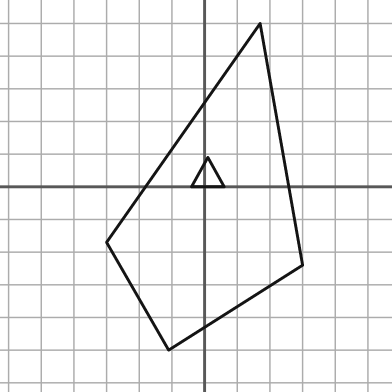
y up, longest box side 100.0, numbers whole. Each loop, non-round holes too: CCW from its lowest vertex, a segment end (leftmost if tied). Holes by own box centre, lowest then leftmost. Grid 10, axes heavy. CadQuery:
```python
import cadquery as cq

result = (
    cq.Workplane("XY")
    .moveTo(-11.0, -50.0)
    .lineTo(30.0, -24.0)
    .lineTo(17.0, 50.0)
    .lineTo(-30.0, -17.0)
    .close()
    .moveTo(-4.0, 0.0)
    .lineTo(6.0, 0.0)
    .lineTo(1.0, 9.0)
    .close()
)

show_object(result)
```